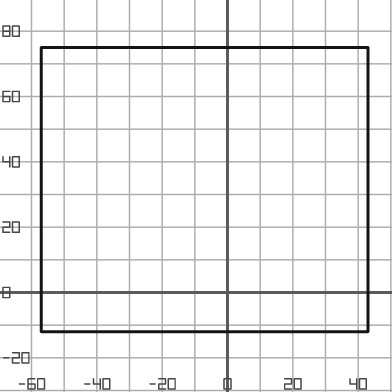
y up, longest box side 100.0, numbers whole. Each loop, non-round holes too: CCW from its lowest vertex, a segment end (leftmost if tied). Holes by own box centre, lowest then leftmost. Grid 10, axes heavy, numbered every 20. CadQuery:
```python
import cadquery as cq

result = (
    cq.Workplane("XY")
    .moveTo(-57.0, -12.0)
    .lineTo(43.0, -12.0)
    .lineTo(43.0, 75.0)
    .lineTo(-57.0, 75.0)
    .close()
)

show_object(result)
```